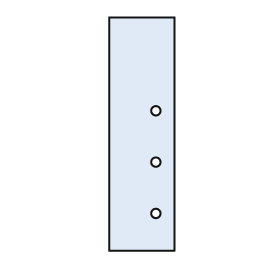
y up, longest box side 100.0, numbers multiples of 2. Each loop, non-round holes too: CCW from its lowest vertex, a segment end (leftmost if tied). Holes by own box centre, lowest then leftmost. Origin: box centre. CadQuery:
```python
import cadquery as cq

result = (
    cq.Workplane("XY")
    .moveTo(-14.0, -50.0)
    .lineTo(14.0, -50.0)
    .lineTo(14.0, 50.0)
    .lineTo(-14.0, 50.0)
    .close()
    .moveTo(6.0, -34.0)
    .circle(2.0)
    .moveTo(6.0, -12.0)
    .circle(2.0)
    .moveTo(6.0, 10.0)
    .circle(2.0)
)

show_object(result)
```